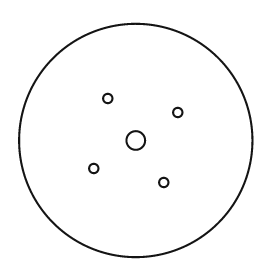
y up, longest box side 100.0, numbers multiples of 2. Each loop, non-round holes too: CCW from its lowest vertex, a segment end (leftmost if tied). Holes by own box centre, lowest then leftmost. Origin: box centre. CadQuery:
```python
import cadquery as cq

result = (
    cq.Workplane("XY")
    .moveTo(0.0, 0.0)
    .circle(50.0)
    .moveTo(12.0, -18.0)
    .circle(2.0)
    .moveTo(-18.0, -12.0)
    .circle(2.0)
    .moveTo(0.0, 0.0)
    .circle(4.0)
    .moveTo(18.0, 12.0)
    .circle(2.0)
    .moveTo(-12.0, 18.0)
    .circle(2.0)
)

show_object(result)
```